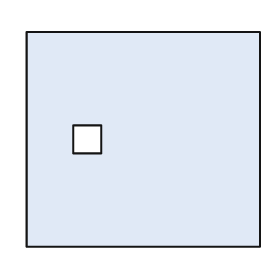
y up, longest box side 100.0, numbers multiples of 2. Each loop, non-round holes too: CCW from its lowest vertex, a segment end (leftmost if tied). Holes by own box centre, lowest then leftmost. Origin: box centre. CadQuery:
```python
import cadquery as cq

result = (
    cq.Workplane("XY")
    .moveTo(-50.0, -46.0)
    .lineTo(50.0, -46.0)
    .lineTo(50.0, 46.0)
    .lineTo(-50.0, 46.0)
    .close()
    .moveTo(-30.0, -6.0)
    .lineTo(-18.0, -6.0)
    .lineTo(-18.0, 6.0)
    .lineTo(-30.0, 6.0)
    .close()
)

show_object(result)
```